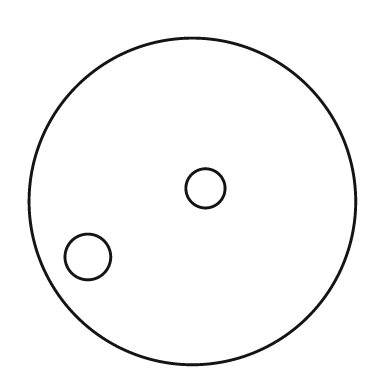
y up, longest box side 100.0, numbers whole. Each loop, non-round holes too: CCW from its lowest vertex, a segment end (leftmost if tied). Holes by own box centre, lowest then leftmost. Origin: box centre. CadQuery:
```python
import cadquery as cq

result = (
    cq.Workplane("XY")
    .moveTo(0.0, 0.0)
    .circle(50.0)
    .moveTo(-32.0, -17.0)
    .circle(7.0)
    .moveTo(4.0, 4.0)
    .circle(6.0)
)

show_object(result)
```